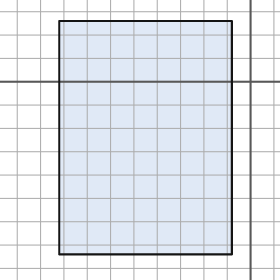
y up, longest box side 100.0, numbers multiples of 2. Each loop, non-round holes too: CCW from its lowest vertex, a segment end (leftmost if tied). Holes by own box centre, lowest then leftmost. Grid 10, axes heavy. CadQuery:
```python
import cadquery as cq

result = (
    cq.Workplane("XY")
    .moveTo(-82.0, -74.0)
    .lineTo(-8.0, -74.0)
    .lineTo(-8.0, 26.0)
    .lineTo(-82.0, 26.0)
    .close()
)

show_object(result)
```